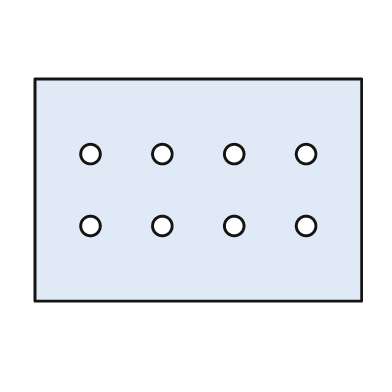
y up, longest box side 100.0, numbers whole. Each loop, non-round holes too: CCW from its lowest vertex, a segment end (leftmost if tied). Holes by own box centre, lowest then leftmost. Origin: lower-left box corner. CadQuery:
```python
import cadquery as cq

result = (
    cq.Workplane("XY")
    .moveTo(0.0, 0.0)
    .lineTo(100.0, 0.0)
    .lineTo(100.0, 68.0)
    .lineTo(0.0, 68.0)
    .close()
    .moveTo(17.0, 23.0)
    .circle(3.0)
    .moveTo(39.0, 23.0)
    .circle(3.0)
    .moveTo(61.0, 23.0)
    .circle(3.0)
    .moveTo(83.0, 23.0)
    .circle(3.0)
    .moveTo(17.0, 45.0)
    .circle(3.0)
    .moveTo(39.0, 45.0)
    .circle(3.0)
    .moveTo(61.0, 45.0)
    .circle(3.0)
    .moveTo(83.0, 45.0)
    .circle(3.0)
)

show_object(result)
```